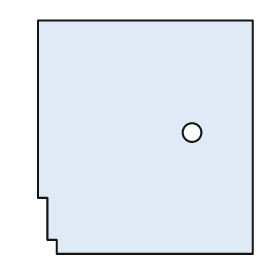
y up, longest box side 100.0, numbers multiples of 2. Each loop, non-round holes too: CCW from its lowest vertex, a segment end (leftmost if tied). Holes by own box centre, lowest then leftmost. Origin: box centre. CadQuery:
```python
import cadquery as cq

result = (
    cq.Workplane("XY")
    .moveTo(-38.0, -50.0)
    .lineTo(46.0, -50.0)
    .lineTo(46.0, 50.0)
    .lineTo(-46.0, 50.0)
    .lineTo(-46.0, -26.0)
    .lineTo(-42.0, -26.0)
    .lineTo(-42.0, -44.0)
    .lineTo(-38.0, -44.0)
    .close()
    .moveTo(20.0, 2.0)
    .circle(4.0)
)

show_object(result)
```